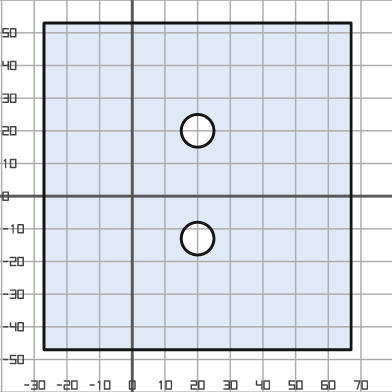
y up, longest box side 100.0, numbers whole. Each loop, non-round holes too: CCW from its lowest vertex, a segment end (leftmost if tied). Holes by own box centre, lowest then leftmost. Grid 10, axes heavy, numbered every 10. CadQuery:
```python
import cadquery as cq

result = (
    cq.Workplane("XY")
    .moveTo(-27.0, -47.0)
    .lineTo(67.0, -47.0)
    .lineTo(67.0, 53.0)
    .lineTo(-27.0, 53.0)
    .close()
    .moveTo(20.0, -13.0)
    .circle(5.0)
    .moveTo(20.0, 20.0)
    .circle(5.0)
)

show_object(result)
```